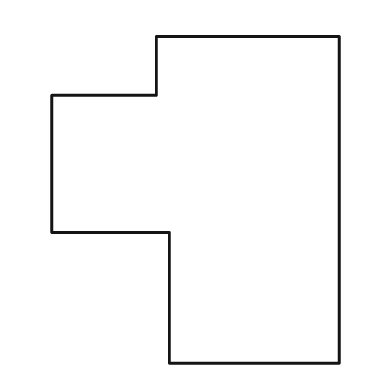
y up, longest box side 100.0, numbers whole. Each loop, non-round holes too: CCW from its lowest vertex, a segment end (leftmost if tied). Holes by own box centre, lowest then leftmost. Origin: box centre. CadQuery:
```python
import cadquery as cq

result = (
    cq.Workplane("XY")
    .moveTo(-8.0, -50.0)
    .lineTo(44.0, -50.0)
    .lineTo(44.0, 50.0)
    .lineTo(-12.0, 50.0)
    .lineTo(-12.0, 32.0)
    .lineTo(-44.0, 32.0)
    .lineTo(-44.0, -10.0)
    .lineTo(-8.0, -10.0)
    .close()
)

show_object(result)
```